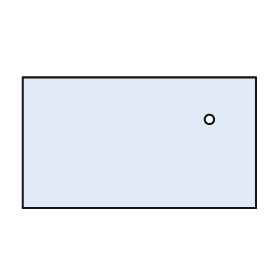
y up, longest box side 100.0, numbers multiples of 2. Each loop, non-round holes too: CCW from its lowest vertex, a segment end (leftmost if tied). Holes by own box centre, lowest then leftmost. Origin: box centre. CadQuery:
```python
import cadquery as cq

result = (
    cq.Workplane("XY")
    .moveTo(-50.0, -28.0)
    .lineTo(50.0, -28.0)
    .lineTo(50.0, 28.0)
    .lineTo(-50.0, 28.0)
    .close()
    .moveTo(30.0, 10.0)
    .circle(2.0)
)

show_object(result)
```